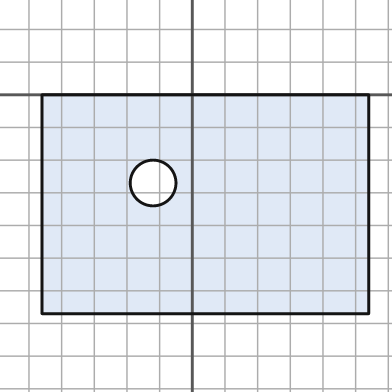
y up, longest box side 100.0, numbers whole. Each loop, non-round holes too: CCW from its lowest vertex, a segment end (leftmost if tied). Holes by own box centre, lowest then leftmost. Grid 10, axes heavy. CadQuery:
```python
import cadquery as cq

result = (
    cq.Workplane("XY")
    .moveTo(-46.0, -67.0)
    .lineTo(54.0, -67.0)
    .lineTo(54.0, 0.0)
    .lineTo(-46.0, 0.0)
    .close()
    .moveTo(-12.0, -27.0)
    .circle(7.0)
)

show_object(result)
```